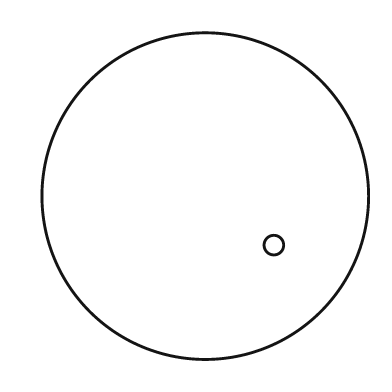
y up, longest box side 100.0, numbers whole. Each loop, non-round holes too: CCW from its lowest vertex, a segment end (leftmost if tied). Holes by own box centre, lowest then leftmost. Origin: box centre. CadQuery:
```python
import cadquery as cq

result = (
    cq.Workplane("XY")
    .moveTo(0.0, 0.0)
    .circle(50.0)
    .moveTo(21.0, -15.0)
    .circle(3.0)
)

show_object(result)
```